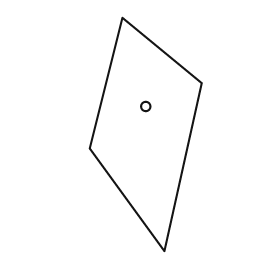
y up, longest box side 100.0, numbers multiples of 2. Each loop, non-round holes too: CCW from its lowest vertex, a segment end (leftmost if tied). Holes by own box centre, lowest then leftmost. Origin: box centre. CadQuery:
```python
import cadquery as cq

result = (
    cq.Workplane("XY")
    .moveTo(8.0, -50.0)
    .lineTo(24.0, 22.0)
    .lineTo(-10.0, 50.0)
    .lineTo(-24.0, -6.0)
    .close()
    .moveTo(0.0, 12.0)
    .circle(2.0)
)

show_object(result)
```